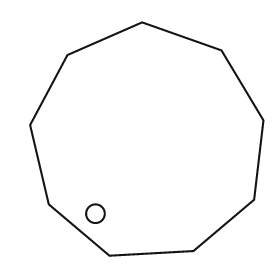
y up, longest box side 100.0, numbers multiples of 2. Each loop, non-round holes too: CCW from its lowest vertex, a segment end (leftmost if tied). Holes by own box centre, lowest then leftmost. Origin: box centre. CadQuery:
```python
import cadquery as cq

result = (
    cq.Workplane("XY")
    .moveTo(-16.0, -50.0)
    .lineTo(20.0, -48.0)
    .lineTo(46.0, -26.0)
    .lineTo(50.0, 8.0)
    .lineTo(32.0, 38.0)
    .lineTo(-2.0, 50.0)
    .lineTo(-34.0, 36.0)
    .lineTo(-50.0, 6.0)
    .lineTo(-42.0, -28.0)
    .close()
    .moveTo(-22.0, -32.0)
    .circle(4.0)
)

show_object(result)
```